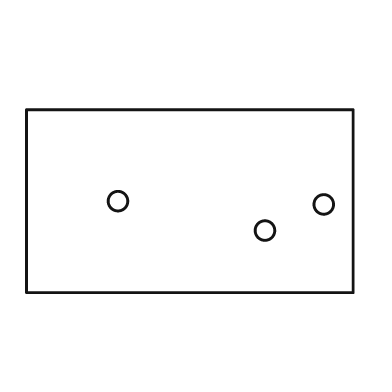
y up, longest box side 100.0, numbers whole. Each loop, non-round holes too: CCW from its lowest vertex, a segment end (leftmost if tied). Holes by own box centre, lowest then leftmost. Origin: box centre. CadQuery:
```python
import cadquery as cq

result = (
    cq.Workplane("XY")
    .moveTo(-50.0, -28.0)
    .lineTo(50.0, -28.0)
    .lineTo(50.0, 28.0)
    .lineTo(-50.0, 28.0)
    .close()
    .moveTo(23.0, -9.0)
    .circle(3.0)
    .moveTo(41.0, -1.0)
    .circle(3.0)
    .moveTo(-22.0, 0.0)
    .circle(3.0)
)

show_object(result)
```